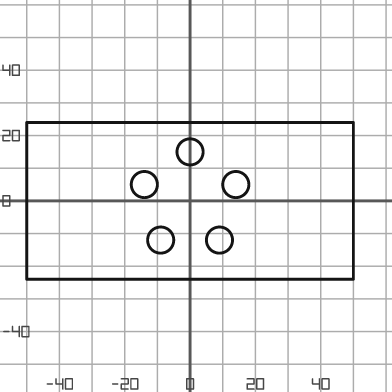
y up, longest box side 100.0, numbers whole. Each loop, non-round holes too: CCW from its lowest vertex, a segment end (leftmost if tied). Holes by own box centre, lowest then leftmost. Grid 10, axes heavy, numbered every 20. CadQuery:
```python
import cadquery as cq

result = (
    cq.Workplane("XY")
    .moveTo(-50.0, -24.0)
    .lineTo(50.0, -24.0)
    .lineTo(50.0, 24.0)
    .lineTo(-50.0, 24.0)
    .close()
    .moveTo(-9.0, -12.0)
    .circle(4.0)
    .moveTo(9.0, -12.0)
    .circle(4.0)
    .moveTo(-14.0, 5.0)
    .circle(4.0)
    .moveTo(14.0, 5.0)
    .circle(4.0)
    .moveTo(0.0, 15.0)
    .circle(4.0)
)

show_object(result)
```